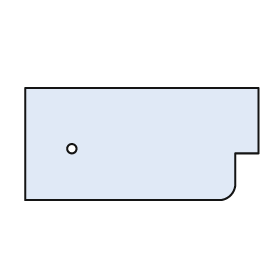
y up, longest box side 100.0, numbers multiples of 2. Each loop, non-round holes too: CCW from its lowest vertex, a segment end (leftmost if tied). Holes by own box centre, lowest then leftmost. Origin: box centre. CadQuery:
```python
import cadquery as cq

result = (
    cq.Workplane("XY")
    .moveTo(-50.0, -24.0)
    .lineTo(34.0, -24.0)
    .threePointArc((38.0, -22.0), (40.0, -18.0))
    .lineTo(40.0, -4.0)
    .lineTo(50.0, -4.0)
    .lineTo(50.0, 24.0)
    .lineTo(-50.0, 24.0)
    .close()
    .moveTo(-30.0, -2.0)
    .circle(2.0)
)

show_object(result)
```